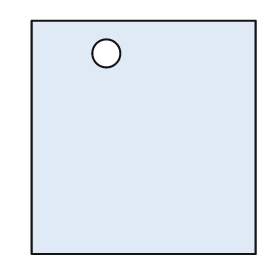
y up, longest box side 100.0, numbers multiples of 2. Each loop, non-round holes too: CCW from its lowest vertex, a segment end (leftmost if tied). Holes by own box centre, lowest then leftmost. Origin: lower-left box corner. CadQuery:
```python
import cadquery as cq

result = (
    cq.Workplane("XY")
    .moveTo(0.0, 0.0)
    .lineTo(96.0, 0.0)
    .lineTo(96.0, 100.0)
    .lineTo(0.0, 100.0)
    .close()
    .moveTo(32.0, 86.0)
    .circle(6.0)
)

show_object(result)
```